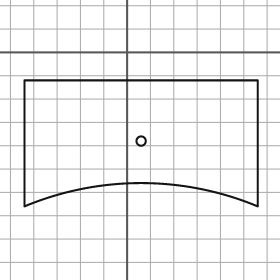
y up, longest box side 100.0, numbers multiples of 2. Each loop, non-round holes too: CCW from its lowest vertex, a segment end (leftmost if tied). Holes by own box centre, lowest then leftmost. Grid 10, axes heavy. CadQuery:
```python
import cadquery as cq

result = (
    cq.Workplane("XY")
    .moveTo(-44.0, -66.0)
    .threePointArc((6.0, -56.0), (56.0, -66.0))
    .lineTo(56.0, -12.0)
    .lineTo(-44.0, -12.0)
    .close()
    .moveTo(6.0, -38.0)
    .circle(2.0)
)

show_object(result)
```